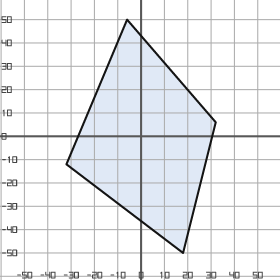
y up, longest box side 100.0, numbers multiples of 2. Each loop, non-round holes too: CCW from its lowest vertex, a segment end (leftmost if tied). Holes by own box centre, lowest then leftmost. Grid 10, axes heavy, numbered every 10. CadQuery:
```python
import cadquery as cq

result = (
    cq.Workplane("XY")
    .moveTo(18.0, -50.0)
    .lineTo(32.0, 6.0)
    .lineTo(-6.0, 50.0)
    .lineTo(-32.0, -12.0)
    .close()
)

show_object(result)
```